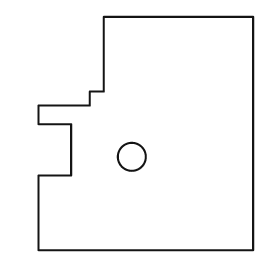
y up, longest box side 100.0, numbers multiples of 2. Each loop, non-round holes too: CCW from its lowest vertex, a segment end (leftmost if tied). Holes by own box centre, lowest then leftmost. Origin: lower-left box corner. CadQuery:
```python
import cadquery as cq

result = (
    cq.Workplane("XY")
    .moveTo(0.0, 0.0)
    .lineTo(92.0, 0.0)
    .lineTo(92.0, 100.0)
    .lineTo(28.0, 100.0)
    .lineTo(28.0, 68.0)
    .lineTo(22.0, 68.0)
    .lineTo(22.0, 62.0)
    .lineTo(0.0, 62.0)
    .lineTo(0.0, 54.0)
    .lineTo(14.0, 54.0)
    .lineTo(14.0, 32.0)
    .lineTo(0.0, 32.0)
    .close()
    .moveTo(40.0, 40.0)
    .circle(6.0)
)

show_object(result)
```